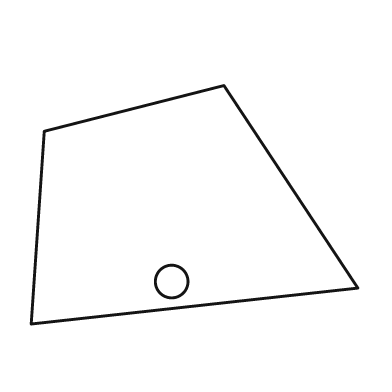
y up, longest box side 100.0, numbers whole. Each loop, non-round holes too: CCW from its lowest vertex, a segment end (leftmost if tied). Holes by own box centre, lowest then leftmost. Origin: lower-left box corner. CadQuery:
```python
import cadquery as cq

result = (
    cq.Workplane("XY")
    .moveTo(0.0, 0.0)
    .lineTo(100.0, 11.0)
    .lineTo(59.0, 73.0)
    .lineTo(4.0, 59.0)
    .close()
    .moveTo(43.0, 13.0)
    .circle(5.0)
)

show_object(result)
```